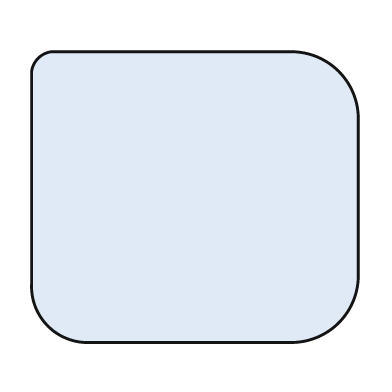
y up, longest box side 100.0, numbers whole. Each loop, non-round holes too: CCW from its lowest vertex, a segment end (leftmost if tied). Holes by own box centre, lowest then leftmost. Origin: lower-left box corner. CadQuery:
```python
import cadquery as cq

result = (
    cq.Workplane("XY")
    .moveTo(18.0, 0.0)
    .lineTo(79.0, 0.0)
    .threePointArc((94.0, 6.0), (100.0, 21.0))
    .lineTo(100.0, 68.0)
    .threePointArc((94.0, 83.0), (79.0, 89.0))
    .lineTo(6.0, 89.0)
    .threePointArc((2.0, 87.0), (0.0, 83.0))
    .lineTo(0.0, 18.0)
    .threePointArc((5.0, 5.0), (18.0, 0.0))
    .close()
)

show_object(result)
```